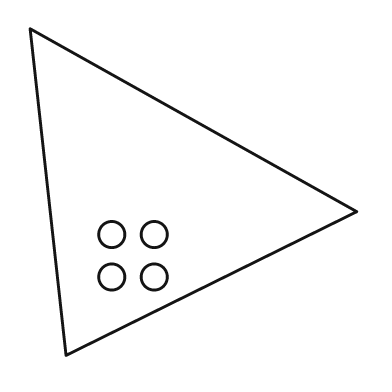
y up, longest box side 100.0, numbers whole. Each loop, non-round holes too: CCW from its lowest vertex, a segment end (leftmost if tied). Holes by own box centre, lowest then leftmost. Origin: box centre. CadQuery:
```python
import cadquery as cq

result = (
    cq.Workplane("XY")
    .moveTo(-39.0, -50.0)
    .lineTo(50.0, -6.0)
    .lineTo(-50.0, 50.0)
    .close()
    .moveTo(-25.0, -26.0)
    .circle(4.0)
    .moveTo(-12.0, -26.0)
    .circle(4.0)
    .moveTo(-25.0, -13.0)
    .circle(4.0)
    .moveTo(-12.0, -13.0)
    .circle(4.0)
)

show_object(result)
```